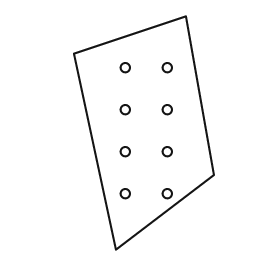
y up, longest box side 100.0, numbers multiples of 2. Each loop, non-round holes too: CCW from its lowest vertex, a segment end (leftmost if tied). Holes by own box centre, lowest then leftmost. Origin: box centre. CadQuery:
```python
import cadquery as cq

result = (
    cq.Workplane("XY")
    .moveTo(-12.0, -50.0)
    .lineTo(30.0, -18.0)
    .lineTo(18.0, 50.0)
    .lineTo(-30.0, 34.0)
    .close()
    .moveTo(-8.0, -26.0)
    .circle(2.0)
    .moveTo(10.0, -26.0)
    .circle(2.0)
    .moveTo(-8.0, -8.0)
    .circle(2.0)
    .moveTo(10.0, -8.0)
    .circle(2.0)
    .moveTo(-8.0, 10.0)
    .circle(2.0)
    .moveTo(10.0, 10.0)
    .circle(2.0)
    .moveTo(-8.0, 28.0)
    .circle(2.0)
    .moveTo(10.0, 28.0)
    .circle(2.0)
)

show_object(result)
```